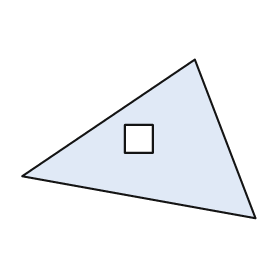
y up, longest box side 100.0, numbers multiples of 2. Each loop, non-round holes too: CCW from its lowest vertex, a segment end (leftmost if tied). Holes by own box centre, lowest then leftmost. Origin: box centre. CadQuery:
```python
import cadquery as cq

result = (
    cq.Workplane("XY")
    .moveTo(50.0, -34.0)
    .lineTo(24.0, 34.0)
    .lineTo(-50.0, -16.0)
    .close()
    .moveTo(-6.0, -6.0)
    .lineTo(6.0, -6.0)
    .lineTo(6.0, 6.0)
    .lineTo(-6.0, 6.0)
    .close()
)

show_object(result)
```